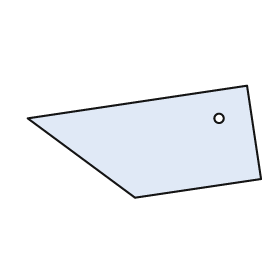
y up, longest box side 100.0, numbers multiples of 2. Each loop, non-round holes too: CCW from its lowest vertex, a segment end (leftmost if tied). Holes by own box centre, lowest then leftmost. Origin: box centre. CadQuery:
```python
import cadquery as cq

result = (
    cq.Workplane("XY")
    .moveTo(-4.0, -24.0)
    .lineTo(50.0, -16.0)
    .lineTo(44.0, 24.0)
    .lineTo(-50.0, 10.0)
    .close()
    .moveTo(32.0, 10.0)
    .circle(2.0)
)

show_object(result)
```